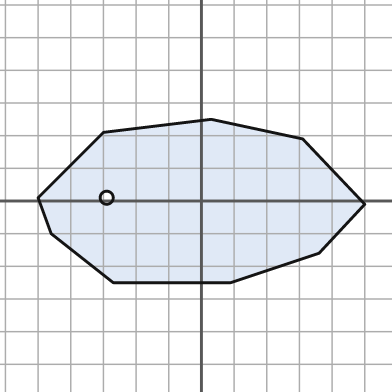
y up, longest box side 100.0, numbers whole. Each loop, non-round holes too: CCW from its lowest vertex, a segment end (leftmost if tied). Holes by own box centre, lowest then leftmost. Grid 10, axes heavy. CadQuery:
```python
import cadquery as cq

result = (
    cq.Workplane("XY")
    .moveTo(-27.0, -25.0)
    .lineTo(9.0, -25.0)
    .lineTo(36.0, -16.0)
    .lineTo(50.0, -1.0)
    .lineTo(31.0, 19.0)
    .lineTo(3.0, 25.0)
    .lineTo(-30.0, 21.0)
    .lineTo(-50.0, 1.0)
    .lineTo(-46.0, -10.0)
    .close()
    .moveTo(-29.0, 1.0)
    .circle(2.0)
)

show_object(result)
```